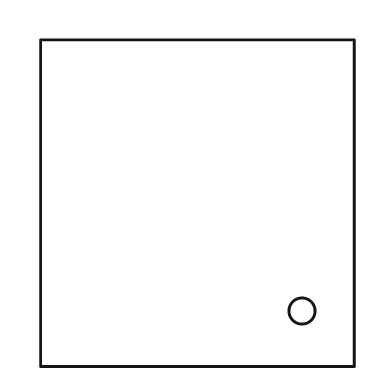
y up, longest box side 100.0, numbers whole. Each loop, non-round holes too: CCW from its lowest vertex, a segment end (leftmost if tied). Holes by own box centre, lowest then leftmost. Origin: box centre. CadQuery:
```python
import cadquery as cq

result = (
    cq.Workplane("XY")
    .moveTo(-48.0, -50.0)
    .lineTo(48.0, -50.0)
    .lineTo(48.0, 50.0)
    .lineTo(-48.0, 50.0)
    .close()
    .moveTo(32.0, -33.0)
    .circle(4.0)
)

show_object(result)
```